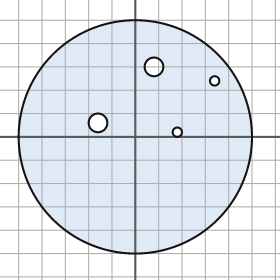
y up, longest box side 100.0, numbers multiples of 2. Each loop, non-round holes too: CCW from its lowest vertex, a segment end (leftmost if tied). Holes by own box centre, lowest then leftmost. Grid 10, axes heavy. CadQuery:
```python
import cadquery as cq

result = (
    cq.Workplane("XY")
    .moveTo(0.0, 0.0)
    .circle(50.0)
    .moveTo(18.0, 2.0)
    .circle(2.0)
    .moveTo(-16.0, 6.0)
    .circle(4.0)
    .moveTo(34.0, 24.0)
    .circle(2.0)
    .moveTo(8.0, 30.0)
    .circle(4.0)
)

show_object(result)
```